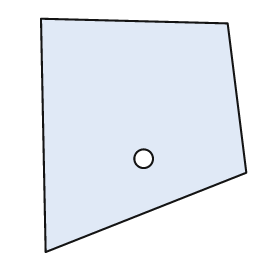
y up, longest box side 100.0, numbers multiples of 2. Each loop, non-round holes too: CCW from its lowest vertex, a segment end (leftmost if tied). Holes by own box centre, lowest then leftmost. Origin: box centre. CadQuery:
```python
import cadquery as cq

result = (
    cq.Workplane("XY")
    .moveTo(-42.0, -50.0)
    .lineTo(44.0, -16.0)
    .lineTo(36.0, 48.0)
    .lineTo(-44.0, 50.0)
    .close()
    .moveTo(0.0, -10.0)
    .circle(4.0)
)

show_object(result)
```